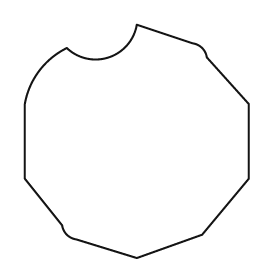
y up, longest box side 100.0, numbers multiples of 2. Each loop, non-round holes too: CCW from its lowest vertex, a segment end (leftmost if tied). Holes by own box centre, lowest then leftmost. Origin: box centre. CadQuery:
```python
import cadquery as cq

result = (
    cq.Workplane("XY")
    .moveTo(0.0, -50.0)
    .lineTo(28.0, -40.0)
    .lineTo(48.0, -16.0)
    .lineTo(48.0, 16.0)
    .lineTo(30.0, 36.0)
    .threePointArc((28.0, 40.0), (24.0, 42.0))
    .lineTo(0.0, 50.0)
    .threePointArc((-12.0, 36.0), (-30.0, 40.0))
    .threePointArc((-42.0, 30.0), (-48.0, 16.0))
    .lineTo(-48.0, -16.0)
    .lineTo(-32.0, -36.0)
    .threePointArc((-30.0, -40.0), (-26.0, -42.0))
    .close()
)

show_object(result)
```